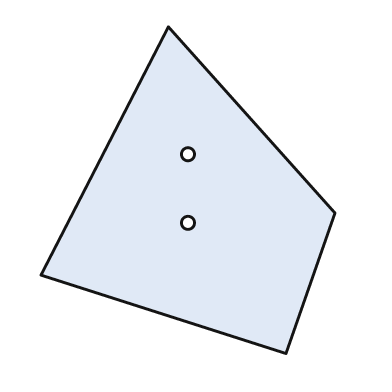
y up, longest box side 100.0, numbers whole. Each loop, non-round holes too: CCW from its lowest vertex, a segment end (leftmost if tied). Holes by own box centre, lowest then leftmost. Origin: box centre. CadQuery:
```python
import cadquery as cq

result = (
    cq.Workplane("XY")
    .moveTo(30.0, -50.0)
    .lineTo(45.0, -7.0)
    .lineTo(-6.0, 50.0)
    .lineTo(-45.0, -26.0)
    .close()
    .moveTo(0.0, -10.0)
    .circle(2.0)
    .moveTo(0.0, 11.0)
    .circle(2.0)
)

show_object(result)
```